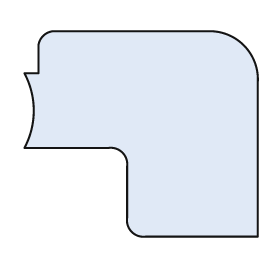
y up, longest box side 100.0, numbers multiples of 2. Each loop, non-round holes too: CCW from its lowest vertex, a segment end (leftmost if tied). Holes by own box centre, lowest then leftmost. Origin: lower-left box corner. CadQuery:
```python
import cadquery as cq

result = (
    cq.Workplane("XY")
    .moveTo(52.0, 0.0)
    .lineTo(100.0, 0.0)
    .lineTo(100.0, 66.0)
    .threePointArc((94.0, 82.0), (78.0, 88.0))
    .lineTo(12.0, 88.0)
    .threePointArc((8.0, 86.0), (6.0, 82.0))
    .lineTo(6.0, 70.0)
    .lineTo(0.0, 70.0)
    .threePointArc((4.0, 54.0), (0.0, 38.0))
    .lineTo(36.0, 38.0)
    .threePointArc((42.0, 36.0), (44.0, 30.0))
    .lineTo(44.0, 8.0)
    .threePointArc((46.0, 2.0), (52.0, 0.0))
    .close()
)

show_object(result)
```